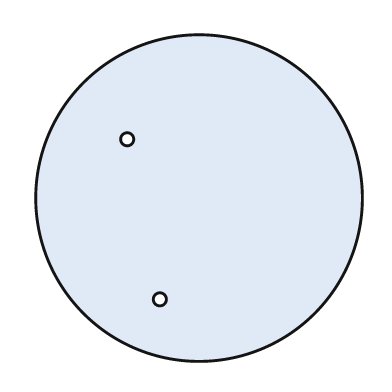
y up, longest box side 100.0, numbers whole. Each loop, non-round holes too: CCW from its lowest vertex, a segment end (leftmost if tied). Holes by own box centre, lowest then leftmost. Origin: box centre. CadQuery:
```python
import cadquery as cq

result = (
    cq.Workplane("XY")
    .moveTo(0.0, 0.0)
    .circle(50.0)
    .moveTo(-12.0, -31.0)
    .circle(2.0)
    .moveTo(-22.0, 18.0)
    .circle(2.0)
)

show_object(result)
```